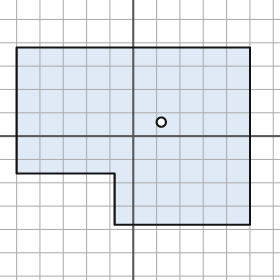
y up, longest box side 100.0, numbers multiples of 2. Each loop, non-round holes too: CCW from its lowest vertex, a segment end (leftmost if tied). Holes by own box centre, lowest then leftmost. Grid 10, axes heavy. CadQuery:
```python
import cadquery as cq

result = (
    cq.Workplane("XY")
    .moveTo(-8.0, -38.0)
    .lineTo(50.0, -38.0)
    .lineTo(50.0, 38.0)
    .lineTo(-50.0, 38.0)
    .lineTo(-50.0, -16.0)
    .lineTo(-8.0, -16.0)
    .close()
    .moveTo(12.0, 6.0)
    .circle(2.0)
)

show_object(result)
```